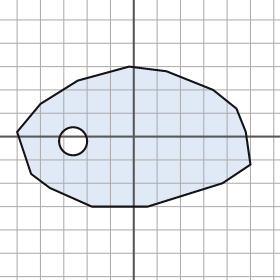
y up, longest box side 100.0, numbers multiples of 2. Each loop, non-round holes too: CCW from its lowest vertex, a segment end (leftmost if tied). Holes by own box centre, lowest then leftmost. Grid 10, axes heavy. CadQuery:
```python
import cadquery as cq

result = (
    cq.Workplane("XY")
    .moveTo(-18.0, -30.0)
    .lineTo(6.0, -30.0)
    .lineTo(38.0, -20.0)
    .lineTo(50.0, -12.0)
    .lineTo(48.0, 2.0)
    .lineTo(44.0, 12.0)
    .lineTo(34.0, 20.0)
    .lineTo(14.0, 28.0)
    .lineTo(-2.0, 30.0)
    .lineTo(-24.0, 24.0)
    .lineTo(-40.0, 14.0)
    .lineTo(-50.0, 2.0)
    .lineTo(-44.0, -16.0)
    .lineTo(-36.0, -22.0)
    .close()
    .moveTo(-26.0, -2.0)
    .circle(6.0)
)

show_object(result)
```